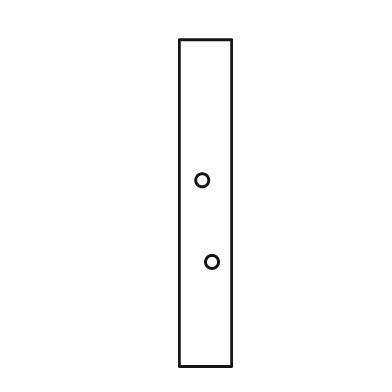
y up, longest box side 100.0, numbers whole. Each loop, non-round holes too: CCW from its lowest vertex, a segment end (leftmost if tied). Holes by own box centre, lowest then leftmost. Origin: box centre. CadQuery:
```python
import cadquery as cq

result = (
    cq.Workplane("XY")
    .moveTo(-8.0, -50.0)
    .lineTo(8.0, -50.0)
    .lineTo(8.0, 50.0)
    .lineTo(-8.0, 50.0)
    .close()
    .moveTo(2.0, -18.0)
    .circle(2.0)
    .moveTo(-1.0, 7.0)
    .circle(2.0)
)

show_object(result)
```